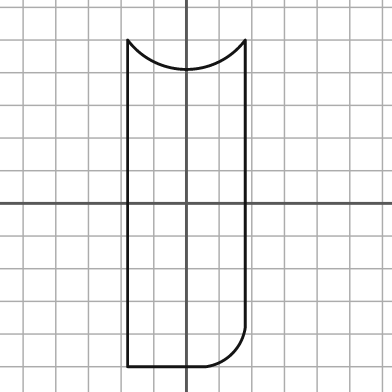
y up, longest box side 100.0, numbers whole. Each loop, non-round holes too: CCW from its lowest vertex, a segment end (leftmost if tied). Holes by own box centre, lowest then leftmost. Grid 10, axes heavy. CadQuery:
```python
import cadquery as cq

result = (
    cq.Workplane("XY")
    .moveTo(-18.0, -50.0)
    .lineTo(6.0, -50.0)
    .threePointArc((14.0, -46.0), (18.0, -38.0))
    .lineTo(18.0, 50.0)
    .threePointArc((0.0, 41.0), (-18.0, 50.0))
    .close()
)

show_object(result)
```